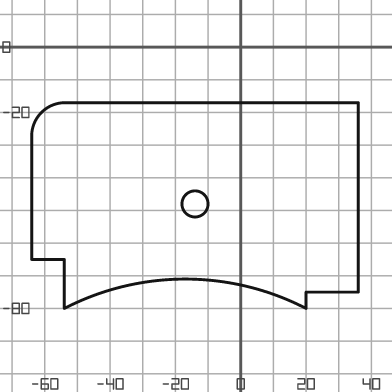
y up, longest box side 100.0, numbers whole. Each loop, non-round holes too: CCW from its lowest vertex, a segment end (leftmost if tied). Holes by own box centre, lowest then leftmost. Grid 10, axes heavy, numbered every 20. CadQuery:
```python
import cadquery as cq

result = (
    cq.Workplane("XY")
    .moveTo(-54.0, -80.0)
    .threePointArc((-17.0, -71.0), (20.0, -80.0))
    .lineTo(20.0, -75.0)
    .lineTo(36.0, -75.0)
    .lineTo(36.0, -17.0)
    .lineTo(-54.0, -17.0)
    .threePointArc((-61.0, -20.0), (-64.0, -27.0))
    .lineTo(-64.0, -65.0)
    .lineTo(-54.0, -65.0)
    .close()
    .moveTo(-14.0, -48.0)
    .circle(4.0)
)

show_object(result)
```